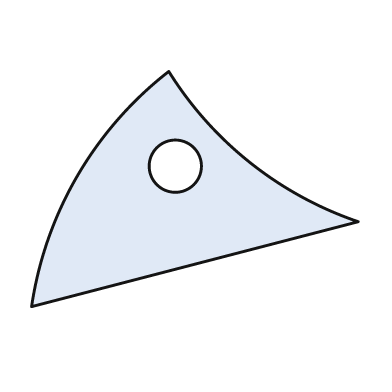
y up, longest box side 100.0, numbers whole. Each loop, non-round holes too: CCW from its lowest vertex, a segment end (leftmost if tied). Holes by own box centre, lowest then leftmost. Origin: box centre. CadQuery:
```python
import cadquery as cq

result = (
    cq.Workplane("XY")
    .moveTo(-50.0, -36.0)
    .lineTo(50.0, -10.0)
    .threePointArc((17.0, 8.0), (-8.0, 36.0))
    .threePointArc((-36.0, 4.0), (-50.0, -36.0))
    .close()
    .moveTo(-6.0, 7.0)
    .circle(8.0)
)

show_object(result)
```